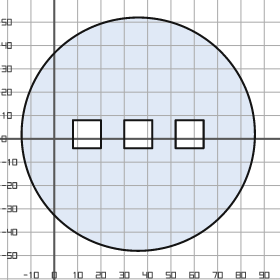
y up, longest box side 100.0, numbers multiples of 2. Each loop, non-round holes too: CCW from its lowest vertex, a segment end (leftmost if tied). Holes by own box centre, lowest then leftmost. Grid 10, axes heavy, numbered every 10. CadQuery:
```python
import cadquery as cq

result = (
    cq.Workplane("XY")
    .moveTo(36.0, 2.0)
    .circle(50.0)
    .moveTo(8.0, -4.0)
    .lineTo(20.0, -4.0)
    .lineTo(20.0, 8.0)
    .lineTo(8.0, 8.0)
    .close()
    .moveTo(30.0, -4.0)
    .lineTo(42.0, -4.0)
    .lineTo(42.0, 8.0)
    .lineTo(30.0, 8.0)
    .close()
    .moveTo(52.0, -4.0)
    .lineTo(64.0, -4.0)
    .lineTo(64.0, 8.0)
    .lineTo(52.0, 8.0)
    .close()
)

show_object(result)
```